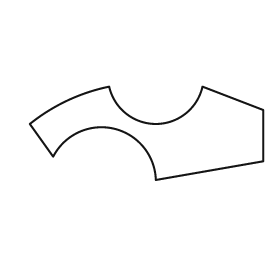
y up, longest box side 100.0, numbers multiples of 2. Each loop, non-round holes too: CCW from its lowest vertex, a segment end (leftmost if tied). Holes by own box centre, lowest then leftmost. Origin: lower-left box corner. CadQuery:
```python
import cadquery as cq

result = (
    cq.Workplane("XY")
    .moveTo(54.0, 0.0)
    .lineTo(100.0, 8.0)
    .lineTo(100.0, 30.0)
    .lineTo(74.0, 40.0)
    .threePointArc((54.0, 24.0), (34.0, 40.0))
    .threePointArc((16.0, 34.0), (0.0, 24.0))
    .lineTo(10.0, 10.0)
    .threePointArc((36.0, 22.0), (54.0, 0.0))
    .close()
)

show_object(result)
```